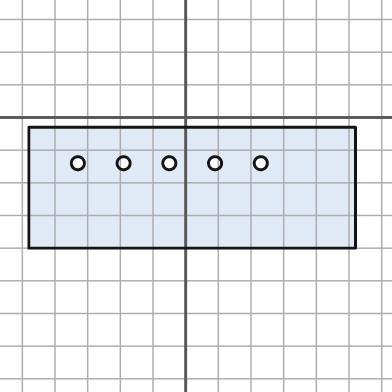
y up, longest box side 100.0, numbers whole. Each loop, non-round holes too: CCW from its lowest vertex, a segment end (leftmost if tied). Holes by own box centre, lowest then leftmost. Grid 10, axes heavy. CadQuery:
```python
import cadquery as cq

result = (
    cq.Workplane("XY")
    .moveTo(-48.0, -40.0)
    .lineTo(52.0, -40.0)
    .lineTo(52.0, -3.0)
    .lineTo(-48.0, -3.0)
    .close()
    .moveTo(-33.0, -14.0)
    .circle(2.0)
    .moveTo(-19.0, -14.0)
    .circle(2.0)
    .moveTo(-5.0, -14.0)
    .circle(2.0)
    .moveTo(9.0, -14.0)
    .circle(2.0)
    .moveTo(23.0, -14.0)
    .circle(2.0)
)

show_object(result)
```